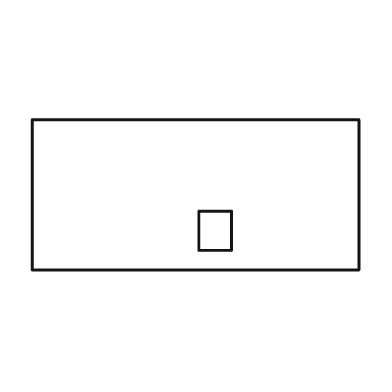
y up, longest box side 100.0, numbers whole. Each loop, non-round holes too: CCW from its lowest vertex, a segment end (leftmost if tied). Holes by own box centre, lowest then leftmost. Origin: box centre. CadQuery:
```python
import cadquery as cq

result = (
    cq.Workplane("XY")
    .moveTo(-50.0, -23.0)
    .lineTo(50.0, -23.0)
    .lineTo(50.0, 23.0)
    .lineTo(-50.0, 23.0)
    .close()
    .moveTo(1.0, -17.0)
    .lineTo(11.0, -17.0)
    .lineTo(11.0, -5.0)
    .lineTo(1.0, -5.0)
    .close()
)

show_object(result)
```